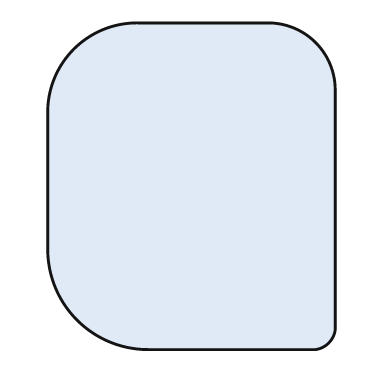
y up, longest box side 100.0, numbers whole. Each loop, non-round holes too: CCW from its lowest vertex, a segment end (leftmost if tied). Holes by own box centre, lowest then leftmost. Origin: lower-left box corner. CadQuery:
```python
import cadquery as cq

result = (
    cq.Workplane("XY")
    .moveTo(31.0, 0.0)
    .lineTo(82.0, 0.0)
    .threePointArc((86.0, 2.0), (88.0, 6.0))
    .lineTo(88.0, 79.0)
    .threePointArc((82.0, 94.0), (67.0, 100.0))
    .lineTo(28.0, 100.0)
    .threePointArc((8.0, 92.0), (0.0, 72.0))
    .lineTo(0.0, 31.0)
    .threePointArc((9.0, 9.0), (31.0, 0.0))
    .close()
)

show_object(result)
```